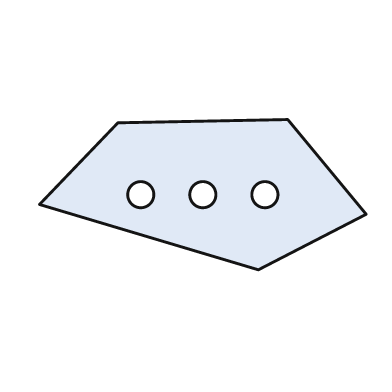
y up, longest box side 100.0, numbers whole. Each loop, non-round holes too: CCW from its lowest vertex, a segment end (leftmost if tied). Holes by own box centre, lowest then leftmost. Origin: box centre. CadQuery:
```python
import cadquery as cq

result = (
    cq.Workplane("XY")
    .moveTo(17.0, -23.0)
    .lineTo(50.0, -6.0)
    .lineTo(26.0, 23.0)
    .lineTo(-26.0, 22.0)
    .lineTo(-50.0, -3.0)
    .close()
    .moveTo(-19.0, 0.0)
    .circle(4.0)
    .moveTo(0.0, 0.0)
    .circle(4.0)
    .moveTo(19.0, 0.0)
    .circle(4.0)
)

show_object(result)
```